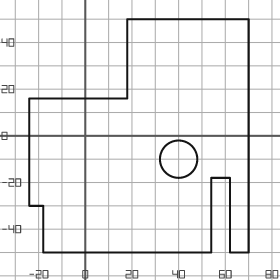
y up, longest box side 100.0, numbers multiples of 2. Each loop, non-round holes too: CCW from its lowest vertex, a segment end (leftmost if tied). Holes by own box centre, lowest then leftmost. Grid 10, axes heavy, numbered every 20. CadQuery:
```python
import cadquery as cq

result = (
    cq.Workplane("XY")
    .moveTo(-18.0, -50.0)
    .lineTo(54.0, -50.0)
    .lineTo(54.0, -18.0)
    .lineTo(62.0, -18.0)
    .lineTo(62.0, -50.0)
    .lineTo(70.0, -50.0)
    .lineTo(70.0, 50.0)
    .lineTo(18.0, 50.0)
    .lineTo(18.0, 16.0)
    .lineTo(-24.0, 16.0)
    .lineTo(-24.0, -30.0)
    .lineTo(-18.0, -30.0)
    .close()
    .moveTo(40.0, -10.0)
    .circle(8.0)
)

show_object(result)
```